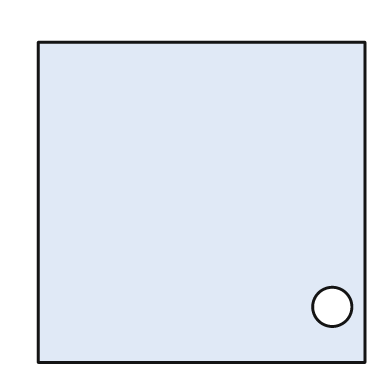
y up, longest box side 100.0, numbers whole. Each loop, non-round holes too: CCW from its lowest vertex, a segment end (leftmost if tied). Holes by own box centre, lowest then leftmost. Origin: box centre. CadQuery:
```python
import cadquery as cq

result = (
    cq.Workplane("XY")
    .moveTo(-50.0, -49.0)
    .lineTo(50.0, -49.0)
    .lineTo(50.0, 49.0)
    .lineTo(-50.0, 49.0)
    .close()
    .moveTo(40.0, -32.0)
    .circle(6.0)
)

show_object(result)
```